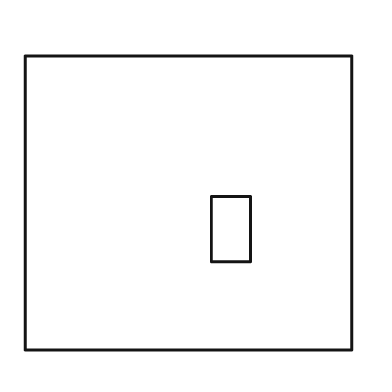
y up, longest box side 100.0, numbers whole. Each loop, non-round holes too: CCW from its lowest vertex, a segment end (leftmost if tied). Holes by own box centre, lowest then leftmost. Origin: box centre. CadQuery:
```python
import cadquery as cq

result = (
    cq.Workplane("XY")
    .moveTo(-50.0, -45.0)
    .lineTo(50.0, -45.0)
    .lineTo(50.0, 45.0)
    .lineTo(-50.0, 45.0)
    .close()
    .moveTo(7.0, -18.0)
    .lineTo(19.0, -18.0)
    .lineTo(19.0, 2.0)
    .lineTo(7.0, 2.0)
    .close()
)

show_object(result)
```